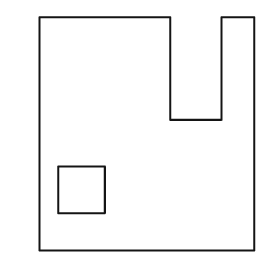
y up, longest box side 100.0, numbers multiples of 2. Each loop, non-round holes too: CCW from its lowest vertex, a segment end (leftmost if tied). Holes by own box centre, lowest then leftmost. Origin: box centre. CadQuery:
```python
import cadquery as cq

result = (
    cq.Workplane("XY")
    .moveTo(-46.0, -50.0)
    .lineTo(46.0, -50.0)
    .lineTo(46.0, 50.0)
    .lineTo(32.0, 50.0)
    .lineTo(32.0, 6.0)
    .lineTo(10.0, 6.0)
    .lineTo(10.0, 50.0)
    .lineTo(-46.0, 50.0)
    .close()
    .moveTo(-38.0, -34.0)
    .lineTo(-18.0, -34.0)
    .lineTo(-18.0, -14.0)
    .lineTo(-38.0, -14.0)
    .close()
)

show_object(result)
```